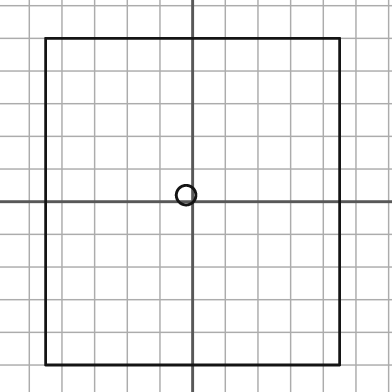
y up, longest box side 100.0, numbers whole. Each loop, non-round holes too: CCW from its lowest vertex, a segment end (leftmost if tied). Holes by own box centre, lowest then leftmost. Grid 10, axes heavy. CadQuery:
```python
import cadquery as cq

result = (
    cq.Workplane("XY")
    .moveTo(-45.0, -50.0)
    .lineTo(45.0, -50.0)
    .lineTo(45.0, 50.0)
    .lineTo(-45.0, 50.0)
    .close()
    .moveTo(-2.0, 2.0)
    .circle(3.0)
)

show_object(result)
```